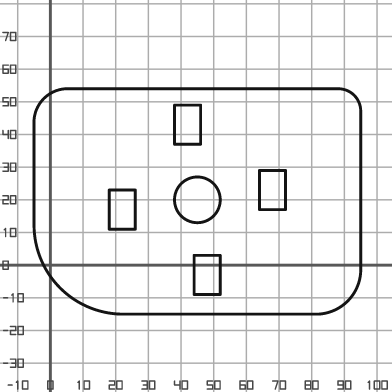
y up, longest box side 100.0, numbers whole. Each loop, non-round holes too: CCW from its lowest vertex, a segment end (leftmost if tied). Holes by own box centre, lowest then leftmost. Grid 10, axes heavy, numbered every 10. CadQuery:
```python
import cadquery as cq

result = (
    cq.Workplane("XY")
    .moveTo(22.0, -15.0)
    .lineTo(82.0, -15.0)
    .threePointArc((91.0, -11.0), (95.0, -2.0))
    .lineTo(95.0, 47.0)
    .threePointArc((93.0, 52.0), (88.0, 54.0))
    .lineTo(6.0, 54.0)
    .threePointArc((-2.0, 51.0), (-5.0, 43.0))
    .lineTo(-5.0, 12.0)
    .threePointArc((3.0, -7.0), (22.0, -15.0))
    .close()
    .moveTo(44.0, -9.0)
    .lineTo(52.0, -9.0)
    .lineTo(52.0, 3.0)
    .lineTo(44.0, 3.0)
    .close()
    .moveTo(18.0, 11.0)
    .lineTo(26.0, 11.0)
    .lineTo(26.0, 23.0)
    .lineTo(18.0, 23.0)
    .close()
    .moveTo(45.0, 20.0)
    .circle(7.0)
    .moveTo(64.0, 17.0)
    .lineTo(72.0, 17.0)
    .lineTo(72.0, 29.0)
    .lineTo(64.0, 29.0)
    .close()
    .moveTo(38.0, 37.0)
    .lineTo(46.0, 37.0)
    .lineTo(46.0, 49.0)
    .lineTo(38.0, 49.0)
    .close()
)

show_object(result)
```